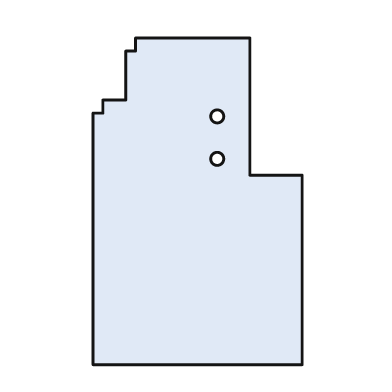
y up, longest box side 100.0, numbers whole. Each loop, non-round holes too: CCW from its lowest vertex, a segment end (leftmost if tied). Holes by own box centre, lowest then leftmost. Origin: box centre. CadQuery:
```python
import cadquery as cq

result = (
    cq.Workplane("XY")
    .moveTo(-32.0, -50.0)
    .lineTo(32.0, -50.0)
    .lineTo(32.0, 8.0)
    .lineTo(16.0, 8.0)
    .lineTo(16.0, 50.0)
    .lineTo(-19.0, 50.0)
    .lineTo(-19.0, 46.0)
    .lineTo(-22.0, 46.0)
    .lineTo(-22.0, 31.0)
    .lineTo(-29.0, 31.0)
    .lineTo(-29.0, 27.0)
    .lineTo(-32.0, 27.0)
    .close()
    .moveTo(6.0, 13.0)
    .circle(2.0)
    .moveTo(6.0, 26.0)
    .circle(2.0)
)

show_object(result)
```